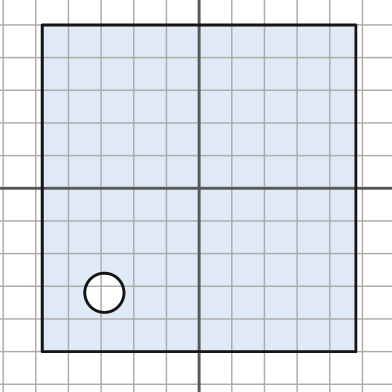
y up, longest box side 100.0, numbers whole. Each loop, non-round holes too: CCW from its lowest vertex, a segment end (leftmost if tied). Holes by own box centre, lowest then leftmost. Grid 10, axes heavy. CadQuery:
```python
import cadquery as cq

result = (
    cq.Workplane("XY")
    .moveTo(-48.0, -50.0)
    .lineTo(48.0, -50.0)
    .lineTo(48.0, 50.0)
    .lineTo(-48.0, 50.0)
    .close()
    .moveTo(-29.0, -32.0)
    .circle(6.0)
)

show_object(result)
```